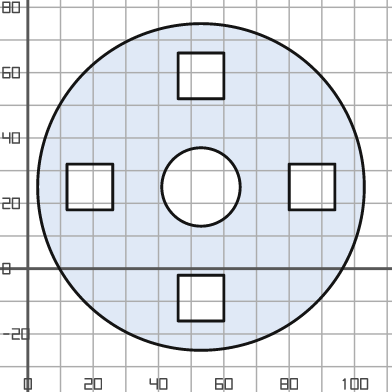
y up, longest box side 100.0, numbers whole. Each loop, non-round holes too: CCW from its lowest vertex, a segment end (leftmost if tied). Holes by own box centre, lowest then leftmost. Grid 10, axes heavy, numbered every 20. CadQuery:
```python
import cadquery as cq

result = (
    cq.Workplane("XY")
    .moveTo(53.0, 25.0)
    .circle(50.0)
    .moveTo(46.0, -16.0)
    .lineTo(60.0, -16.0)
    .lineTo(60.0, -2.0)
    .lineTo(46.0, -2.0)
    .close()
    .moveTo(12.0, 18.0)
    .lineTo(26.0, 18.0)
    .lineTo(26.0, 32.0)
    .lineTo(12.0, 32.0)
    .close()
    .moveTo(53.0, 25.0)
    .circle(12.0)
    .moveTo(80.0, 18.0)
    .lineTo(94.0, 18.0)
    .lineTo(94.0, 32.0)
    .lineTo(80.0, 32.0)
    .close()
    .moveTo(46.0, 52.0)
    .lineTo(60.0, 52.0)
    .lineTo(60.0, 66.0)
    .lineTo(46.0, 66.0)
    .close()
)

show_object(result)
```